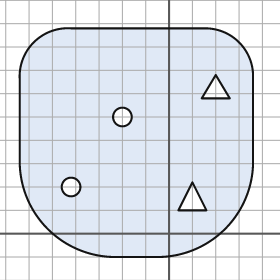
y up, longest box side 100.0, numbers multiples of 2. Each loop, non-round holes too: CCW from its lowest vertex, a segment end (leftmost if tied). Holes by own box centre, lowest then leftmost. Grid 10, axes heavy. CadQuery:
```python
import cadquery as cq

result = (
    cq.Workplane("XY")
    .moveTo(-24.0, -10.0)
    .lineTo(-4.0, -10.0)
    .threePointArc((24.0, 2.0), (36.0, 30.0))
    .lineTo(36.0, 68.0)
    .threePointArc((30.0, 82.0), (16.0, 88.0))
    .lineTo(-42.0, 88.0)
    .threePointArc((-58.0, 82.0), (-64.0, 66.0))
    .lineTo(-64.0, 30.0)
    .threePointArc((-52.0, 2.0), (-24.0, -10.0))
    .close()
    .moveTo(4.0, 10.0)
    .lineTo(16.0, 10.0)
    .lineTo(10.0, 22.0)
    .close()
    .moveTo(-42.0, 20.0)
    .circle(4.0)
    .moveTo(-20.0, 50.0)
    .circle(4.0)
    .moveTo(14.0, 58.0)
    .lineTo(26.0, 58.0)
    .lineTo(20.0, 68.0)
    .close()
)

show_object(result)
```